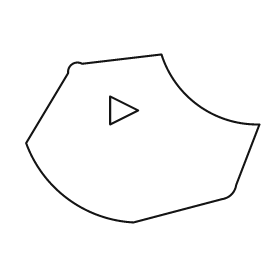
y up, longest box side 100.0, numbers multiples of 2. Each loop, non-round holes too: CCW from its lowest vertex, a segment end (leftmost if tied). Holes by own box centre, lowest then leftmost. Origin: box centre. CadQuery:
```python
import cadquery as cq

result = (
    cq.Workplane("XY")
    .moveTo(-4.0, -36.0)
    .lineTo(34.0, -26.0)
    .threePointArc((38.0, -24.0), (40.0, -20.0))
    .lineTo(50.0, 6.0)
    .threePointArc((24.0, 14.0), (8.0, 36.0))
    .lineTo(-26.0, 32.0)
    .threePointArc((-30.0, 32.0), (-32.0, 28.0))
    .lineTo(-50.0, -2.0)
    .threePointArc((-32.0, -26.0), (-4.0, -36.0))
    .close()
    .moveTo(-14.0, 6.0)
    .lineTo(-2.0, 12.0)
    .lineTo(-14.0, 18.0)
    .close()
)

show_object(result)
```